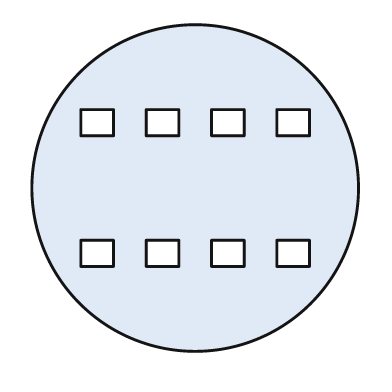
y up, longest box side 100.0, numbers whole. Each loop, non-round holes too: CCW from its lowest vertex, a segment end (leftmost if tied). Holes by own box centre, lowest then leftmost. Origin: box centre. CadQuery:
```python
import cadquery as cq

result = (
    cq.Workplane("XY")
    .moveTo(0.0, 0.0)
    .circle(50.0)
    .moveTo(-35.0, -24.0)
    .lineTo(-25.0, -24.0)
    .lineTo(-25.0, -16.0)
    .lineTo(-35.0, -16.0)
    .close()
    .moveTo(-15.0, -24.0)
    .lineTo(-5.0, -24.0)
    .lineTo(-5.0, -16.0)
    .lineTo(-15.0, -16.0)
    .close()
    .moveTo(5.0, -24.0)
    .lineTo(15.0, -24.0)
    .lineTo(15.0, -16.0)
    .lineTo(5.0, -16.0)
    .close()
    .moveTo(25.0, -24.0)
    .lineTo(35.0, -24.0)
    .lineTo(35.0, -16.0)
    .lineTo(25.0, -16.0)
    .close()
    .moveTo(-35.0, 16.0)
    .lineTo(-25.0, 16.0)
    .lineTo(-25.0, 24.0)
    .lineTo(-35.0, 24.0)
    .close()
    .moveTo(-15.0, 16.0)
    .lineTo(-5.0, 16.0)
    .lineTo(-5.0, 24.0)
    .lineTo(-15.0, 24.0)
    .close()
    .moveTo(5.0, 16.0)
    .lineTo(15.0, 16.0)
    .lineTo(15.0, 24.0)
    .lineTo(5.0, 24.0)
    .close()
    .moveTo(25.0, 16.0)
    .lineTo(35.0, 16.0)
    .lineTo(35.0, 24.0)
    .lineTo(25.0, 24.0)
    .close()
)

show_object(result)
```